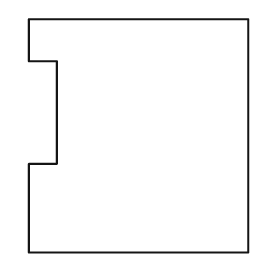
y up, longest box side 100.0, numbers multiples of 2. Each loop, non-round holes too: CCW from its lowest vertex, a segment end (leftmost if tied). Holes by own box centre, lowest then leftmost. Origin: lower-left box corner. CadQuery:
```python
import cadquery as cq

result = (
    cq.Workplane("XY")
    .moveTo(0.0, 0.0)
    .lineTo(94.0, 0.0)
    .lineTo(94.0, 100.0)
    .lineTo(0.0, 100.0)
    .lineTo(0.0, 82.0)
    .lineTo(12.0, 82.0)
    .lineTo(12.0, 38.0)
    .lineTo(0.0, 38.0)
    .close()
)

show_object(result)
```